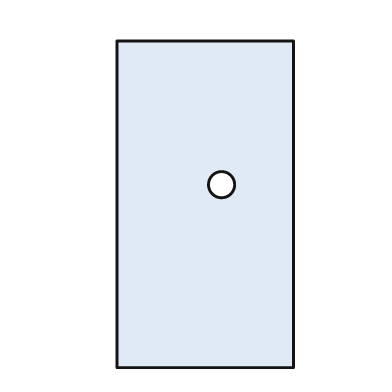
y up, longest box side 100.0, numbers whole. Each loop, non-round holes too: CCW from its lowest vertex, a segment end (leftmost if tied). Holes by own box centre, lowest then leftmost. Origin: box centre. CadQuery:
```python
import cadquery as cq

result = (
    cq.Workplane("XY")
    .moveTo(-27.0, -50.0)
    .lineTo(27.0, -50.0)
    .lineTo(27.0, 50.0)
    .lineTo(-27.0, 50.0)
    .close()
    .moveTo(5.0, 6.0)
    .circle(4.0)
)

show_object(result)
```